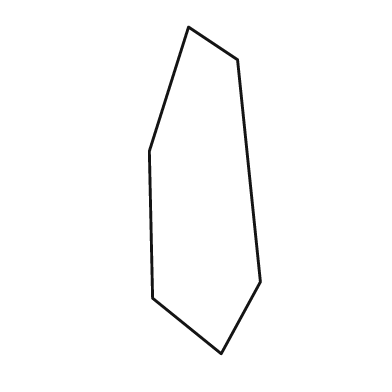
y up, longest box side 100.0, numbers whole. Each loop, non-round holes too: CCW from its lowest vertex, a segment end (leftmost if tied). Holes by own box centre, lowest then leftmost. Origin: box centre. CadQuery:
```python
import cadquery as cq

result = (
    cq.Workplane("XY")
    .moveTo(5.0, -50.0)
    .lineTo(17.0, -28.0)
    .lineTo(10.0, 40.0)
    .lineTo(-5.0, 50.0)
    .lineTo(-17.0, 12.0)
    .lineTo(-16.0, -33.0)
    .close()
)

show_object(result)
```